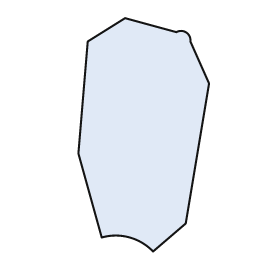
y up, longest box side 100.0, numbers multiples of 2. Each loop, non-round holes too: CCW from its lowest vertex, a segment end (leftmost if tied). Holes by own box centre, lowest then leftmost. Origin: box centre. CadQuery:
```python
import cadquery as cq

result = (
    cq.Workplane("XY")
    .moveTo(4.0, -50.0)
    .lineTo(18.0, -38.0)
    .lineTo(28.0, 22.0)
    .lineTo(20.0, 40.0)
    .threePointArc((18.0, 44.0), (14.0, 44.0))
    .lineTo(-8.0, 50.0)
    .lineTo(-24.0, 40.0)
    .lineTo(-28.0, -8.0)
    .lineTo(-18.0, -44.0)
    .threePointArc((-6.0, -44.0), (4.0, -50.0))
    .close()
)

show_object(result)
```